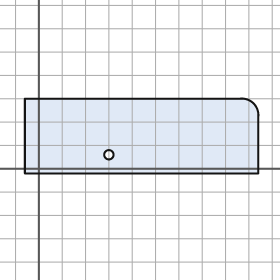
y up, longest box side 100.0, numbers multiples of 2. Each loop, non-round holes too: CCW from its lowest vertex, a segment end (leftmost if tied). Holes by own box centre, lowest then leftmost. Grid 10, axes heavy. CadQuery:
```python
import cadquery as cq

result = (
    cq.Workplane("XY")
    .moveTo(-6.0, -2.0)
    .lineTo(94.0, -2.0)
    .lineTo(94.0, 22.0)
    .threePointArc((92.0, 28.0), (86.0, 30.0))
    .lineTo(-6.0, 30.0)
    .close()
    .moveTo(30.0, 6.0)
    .circle(2.0)
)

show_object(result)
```